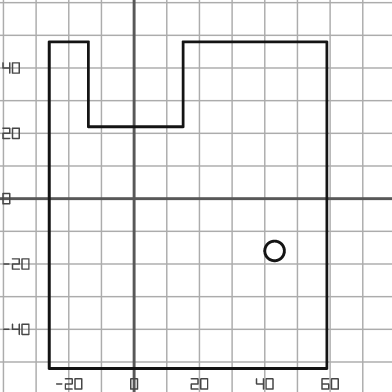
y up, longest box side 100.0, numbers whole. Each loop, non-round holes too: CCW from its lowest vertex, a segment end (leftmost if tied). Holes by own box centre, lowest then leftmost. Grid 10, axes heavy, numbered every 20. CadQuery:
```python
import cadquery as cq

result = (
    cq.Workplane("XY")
    .moveTo(-26.0, -52.0)
    .lineTo(59.0, -52.0)
    .lineTo(59.0, 48.0)
    .lineTo(15.0, 48.0)
    .lineTo(15.0, 22.0)
    .lineTo(-14.0, 22.0)
    .lineTo(-14.0, 48.0)
    .lineTo(-26.0, 48.0)
    .close()
    .moveTo(43.0, -16.0)
    .circle(3.0)
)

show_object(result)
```